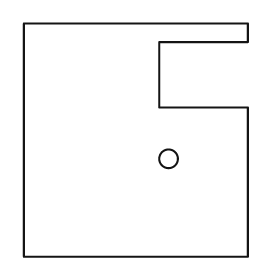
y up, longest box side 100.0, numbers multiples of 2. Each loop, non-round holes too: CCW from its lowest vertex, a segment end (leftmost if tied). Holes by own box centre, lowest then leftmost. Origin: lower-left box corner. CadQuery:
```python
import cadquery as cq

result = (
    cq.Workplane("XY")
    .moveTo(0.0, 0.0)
    .lineTo(96.0, 0.0)
    .lineTo(96.0, 64.0)
    .lineTo(58.0, 64.0)
    .lineTo(58.0, 92.0)
    .lineTo(96.0, 92.0)
    .lineTo(96.0, 100.0)
    .lineTo(0.0, 100.0)
    .close()
    .moveTo(62.0, 42.0)
    .circle(4.0)
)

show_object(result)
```